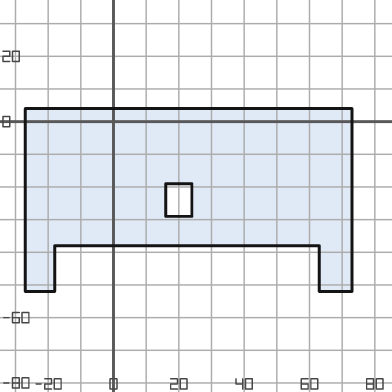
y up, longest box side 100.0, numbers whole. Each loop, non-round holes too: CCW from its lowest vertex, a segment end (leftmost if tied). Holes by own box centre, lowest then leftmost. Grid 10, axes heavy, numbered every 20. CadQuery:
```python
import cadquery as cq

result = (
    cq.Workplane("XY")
    .moveTo(-27.0, -52.0)
    .lineTo(-18.0, -52.0)
    .lineTo(-18.0, -38.0)
    .lineTo(63.0, -38.0)
    .lineTo(63.0, -52.0)
    .lineTo(73.0, -52.0)
    .lineTo(73.0, 4.0)
    .lineTo(-27.0, 4.0)
    .close()
    .moveTo(16.0, -29.0)
    .lineTo(24.0, -29.0)
    .lineTo(24.0, -19.0)
    .lineTo(16.0, -19.0)
    .close()
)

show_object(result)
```